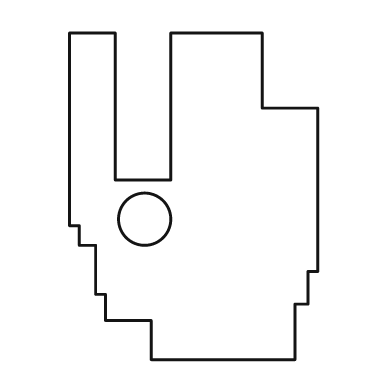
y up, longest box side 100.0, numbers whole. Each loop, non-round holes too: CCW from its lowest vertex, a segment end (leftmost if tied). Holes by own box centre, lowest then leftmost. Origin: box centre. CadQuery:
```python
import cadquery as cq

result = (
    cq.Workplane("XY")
    .moveTo(-13.0, -50.0)
    .lineTo(31.0, -50.0)
    .lineTo(31.0, -33.0)
    .lineTo(35.0, -33.0)
    .lineTo(35.0, -23.0)
    .lineTo(38.0, -23.0)
    .lineTo(38.0, 27.0)
    .lineTo(21.0, 27.0)
    .lineTo(21.0, 50.0)
    .lineTo(-7.0, 50.0)
    .lineTo(-7.0, 5.0)
    .lineTo(-24.0, 5.0)
    .lineTo(-24.0, 50.0)
    .lineTo(-38.0, 50.0)
    .lineTo(-38.0, -9.0)
    .lineTo(-35.0, -9.0)
    .lineTo(-35.0, -15.0)
    .lineTo(-30.0, -15.0)
    .lineTo(-30.0, -30.0)
    .lineTo(-27.0, -30.0)
    .lineTo(-27.0, -38.0)
    .lineTo(-13.0, -38.0)
    .close()
    .moveTo(-15.0, -7.0)
    .circle(8.0)
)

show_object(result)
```